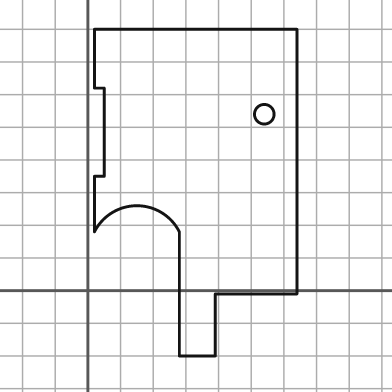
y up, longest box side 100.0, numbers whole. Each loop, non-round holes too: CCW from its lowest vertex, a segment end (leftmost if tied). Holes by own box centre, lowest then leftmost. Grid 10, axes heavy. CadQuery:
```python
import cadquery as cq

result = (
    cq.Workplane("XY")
    .moveTo(28.0, -20.0)
    .lineTo(39.0, -20.0)
    .lineTo(39.0, -1.0)
    .lineTo(64.0, -1.0)
    .lineTo(64.0, 80.0)
    .lineTo(2.0, 80.0)
    .lineTo(2.0, 62.0)
    .lineTo(5.0, 62.0)
    .lineTo(5.0, 35.0)
    .lineTo(2.0, 35.0)
    .lineTo(2.0, 18.0)
    .threePointArc((15.0, 26.0), (28.0, 18.0))
    .close()
    .moveTo(54.0, 54.0)
    .circle(3.0)
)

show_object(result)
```